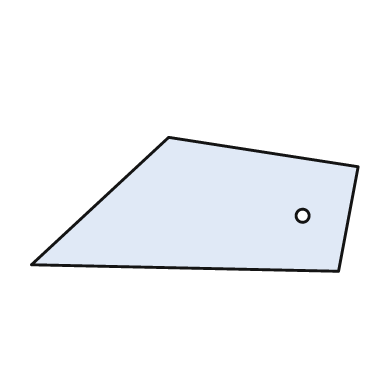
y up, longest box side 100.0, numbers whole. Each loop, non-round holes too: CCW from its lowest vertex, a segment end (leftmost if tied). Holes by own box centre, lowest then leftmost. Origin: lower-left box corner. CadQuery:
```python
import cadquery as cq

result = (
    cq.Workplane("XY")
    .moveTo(94.0, 0.0)
    .lineTo(100.0, 32.0)
    .lineTo(42.0, 41.0)
    .lineTo(0.0, 2.0)
    .close()
    .moveTo(83.0, 17.0)
    .circle(2.0)
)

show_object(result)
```